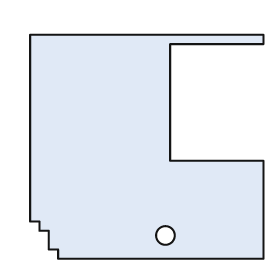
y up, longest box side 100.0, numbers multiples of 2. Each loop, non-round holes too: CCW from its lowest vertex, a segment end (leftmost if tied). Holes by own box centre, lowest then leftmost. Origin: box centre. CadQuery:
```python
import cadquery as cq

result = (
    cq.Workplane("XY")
    .moveTo(-38.0, -48.0)
    .lineTo(50.0, -48.0)
    .lineTo(50.0, -6.0)
    .lineTo(10.0, -6.0)
    .lineTo(10.0, 44.0)
    .lineTo(50.0, 44.0)
    .lineTo(50.0, 48.0)
    .lineTo(-50.0, 48.0)
    .lineTo(-50.0, -32.0)
    .lineTo(-46.0, -32.0)
    .lineTo(-46.0, -36.0)
    .lineTo(-42.0, -36.0)
    .lineTo(-42.0, -44.0)
    .lineTo(-38.0, -44.0)
    .close()
    .moveTo(8.0, -38.0)
    .circle(4.0)
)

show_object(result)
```